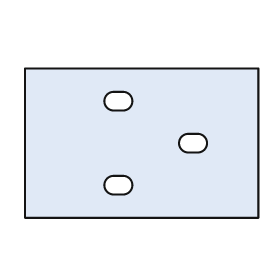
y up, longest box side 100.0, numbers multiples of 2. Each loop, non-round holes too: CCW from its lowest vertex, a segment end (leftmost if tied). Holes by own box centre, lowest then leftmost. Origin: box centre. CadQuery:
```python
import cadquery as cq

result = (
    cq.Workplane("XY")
    .moveTo(-50.0, -32.0)
    .lineTo(50.0, -32.0)
    .lineTo(50.0, 32.0)
    .lineTo(-50.0, 32.0)
    .close()
    .moveTo(-12.0, -22.0)
    .lineTo(-8.0, -22.0)
    .threePointArc((-4.0, -18.0), (-8.0, -14.0))
    .lineTo(-12.0, -14.0)
    .threePointArc((-16.0, -18.0), (-12.0, -22.0))
    .close()
    .moveTo(20.0, -4.0)
    .lineTo(24.0, -4.0)
    .threePointArc((28.0, 0.0), (24.0, 4.0))
    .lineTo(20.0, 4.0)
    .threePointArc((16.0, 0.0), (20.0, -4.0))
    .close()
    .moveTo(-12.0, 14.0)
    .lineTo(-8.0, 14.0)
    .threePointArc((-4.0, 18.0), (-8.0, 22.0))
    .lineTo(-12.0, 22.0)
    .threePointArc((-16.0, 18.0), (-12.0, 14.0))
    .close()
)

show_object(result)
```